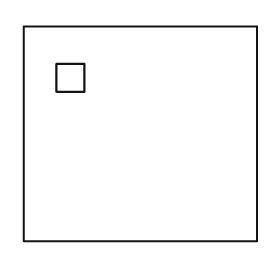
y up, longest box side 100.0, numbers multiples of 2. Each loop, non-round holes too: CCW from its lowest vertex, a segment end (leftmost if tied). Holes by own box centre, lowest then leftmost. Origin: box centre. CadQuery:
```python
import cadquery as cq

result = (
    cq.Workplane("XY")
    .moveTo(-50.0, -46.0)
    .lineTo(50.0, -46.0)
    .lineTo(50.0, 46.0)
    .lineTo(-50.0, 46.0)
    .close()
    .moveTo(-36.0, 18.0)
    .lineTo(-24.0, 18.0)
    .lineTo(-24.0, 30.0)
    .lineTo(-36.0, 30.0)
    .close()
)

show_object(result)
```